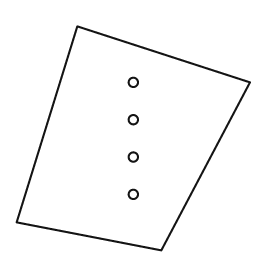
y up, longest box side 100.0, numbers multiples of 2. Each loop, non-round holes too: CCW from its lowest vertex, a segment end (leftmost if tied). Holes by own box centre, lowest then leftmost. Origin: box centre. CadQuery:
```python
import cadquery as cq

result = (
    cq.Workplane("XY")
    .moveTo(12.0, -48.0)
    .lineTo(50.0, 24.0)
    .lineTo(-24.0, 48.0)
    .lineTo(-50.0, -36.0)
    .close()
    .moveTo(0.0, -24.0)
    .circle(2.0)
    .moveTo(0.0, -8.0)
    .circle(2.0)
    .moveTo(0.0, 8.0)
    .circle(2.0)
    .moveTo(0.0, 24.0)
    .circle(2.0)
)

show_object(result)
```